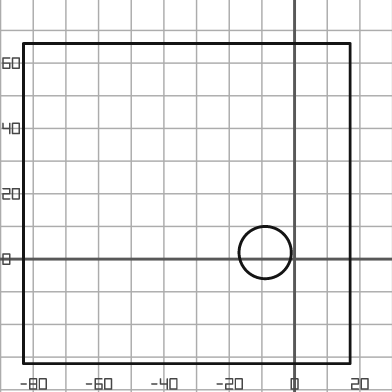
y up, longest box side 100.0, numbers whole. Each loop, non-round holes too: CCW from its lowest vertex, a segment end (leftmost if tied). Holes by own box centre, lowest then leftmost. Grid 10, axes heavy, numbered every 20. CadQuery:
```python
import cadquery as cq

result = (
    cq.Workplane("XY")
    .moveTo(-83.0, -32.0)
    .lineTo(17.0, -32.0)
    .lineTo(17.0, 66.0)
    .lineTo(-83.0, 66.0)
    .close()
    .moveTo(-9.0, 2.0)
    .circle(8.0)
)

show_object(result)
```